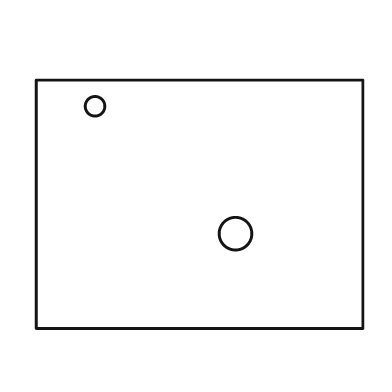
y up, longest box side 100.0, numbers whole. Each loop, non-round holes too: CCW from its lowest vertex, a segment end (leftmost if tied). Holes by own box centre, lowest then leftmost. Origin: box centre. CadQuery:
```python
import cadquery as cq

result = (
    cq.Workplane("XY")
    .moveTo(-50.0, -38.0)
    .lineTo(50.0, -38.0)
    .lineTo(50.0, 38.0)
    .lineTo(-50.0, 38.0)
    .close()
    .moveTo(11.0, -9.0)
    .circle(5.0)
    .moveTo(-32.0, 30.0)
    .circle(3.0)
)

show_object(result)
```